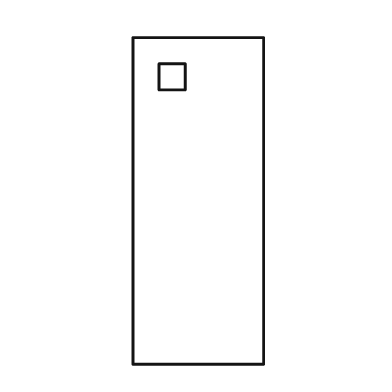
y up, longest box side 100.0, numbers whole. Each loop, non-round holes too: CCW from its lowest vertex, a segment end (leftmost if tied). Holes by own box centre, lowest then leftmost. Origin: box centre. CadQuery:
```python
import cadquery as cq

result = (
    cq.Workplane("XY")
    .moveTo(-20.0, -50.0)
    .lineTo(20.0, -50.0)
    .lineTo(20.0, 50.0)
    .lineTo(-20.0, 50.0)
    .close()
    .moveTo(-12.0, 34.0)
    .lineTo(-4.0, 34.0)
    .lineTo(-4.0, 42.0)
    .lineTo(-12.0, 42.0)
    .close()
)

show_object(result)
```